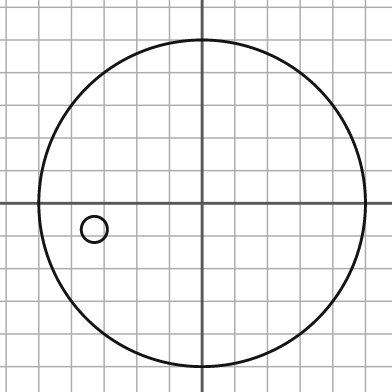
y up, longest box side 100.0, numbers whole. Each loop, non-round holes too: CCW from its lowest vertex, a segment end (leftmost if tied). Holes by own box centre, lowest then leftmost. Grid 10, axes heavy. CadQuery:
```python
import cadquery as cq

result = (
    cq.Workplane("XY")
    .moveTo(0.0, 0.0)
    .circle(50.0)
    .moveTo(-33.0, -8.0)
    .circle(4.0)
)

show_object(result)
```